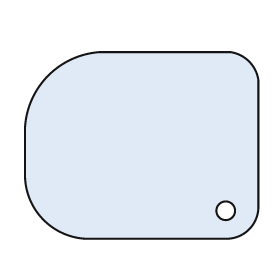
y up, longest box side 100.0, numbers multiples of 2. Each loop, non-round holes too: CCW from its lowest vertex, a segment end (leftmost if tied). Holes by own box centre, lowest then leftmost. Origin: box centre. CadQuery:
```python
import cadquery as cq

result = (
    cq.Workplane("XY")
    .moveTo(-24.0, -40.0)
    .lineTo(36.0, -40.0)
    .threePointArc((46.0, -36.0), (50.0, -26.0))
    .lineTo(50.0, 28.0)
    .threePointArc((46.0, 36.0), (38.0, 40.0))
    .lineTo(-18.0, 40.0)
    .threePointArc((-40.0, 30.0), (-50.0, 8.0))
    .lineTo(-50.0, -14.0)
    .threePointArc((-42.0, -32.0), (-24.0, -40.0))
    .close()
    .moveTo(36.0, -28.0)
    .circle(4.0)
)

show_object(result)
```